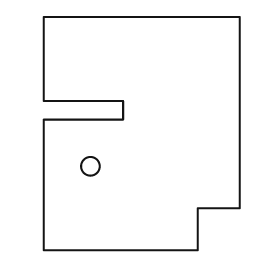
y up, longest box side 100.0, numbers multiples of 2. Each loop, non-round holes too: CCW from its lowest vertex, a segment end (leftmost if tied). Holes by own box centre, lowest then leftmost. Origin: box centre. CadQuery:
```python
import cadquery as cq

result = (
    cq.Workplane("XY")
    .moveTo(-42.0, -50.0)
    .lineTo(24.0, -50.0)
    .lineTo(24.0, -32.0)
    .lineTo(42.0, -32.0)
    .lineTo(42.0, 50.0)
    .lineTo(-42.0, 50.0)
    .lineTo(-42.0, 14.0)
    .lineTo(-8.0, 14.0)
    .lineTo(-8.0, 6.0)
    .lineTo(-42.0, 6.0)
    .close()
    .moveTo(-22.0, -14.0)
    .circle(4.0)
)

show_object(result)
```